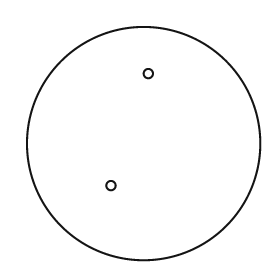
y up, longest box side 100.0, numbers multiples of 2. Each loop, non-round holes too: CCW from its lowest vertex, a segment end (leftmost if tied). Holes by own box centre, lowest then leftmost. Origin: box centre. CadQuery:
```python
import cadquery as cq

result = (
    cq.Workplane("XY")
    .moveTo(0.0, 0.0)
    .circle(50.0)
    .moveTo(-14.0, -18.0)
    .circle(2.0)
    .moveTo(2.0, 30.0)
    .circle(2.0)
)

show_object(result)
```